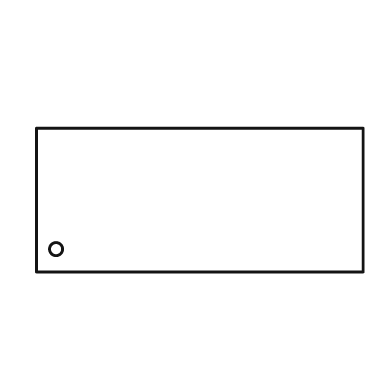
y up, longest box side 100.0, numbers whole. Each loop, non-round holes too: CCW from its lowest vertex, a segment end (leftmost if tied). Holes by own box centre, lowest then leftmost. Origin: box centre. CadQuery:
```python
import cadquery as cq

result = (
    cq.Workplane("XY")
    .moveTo(-50.0, -22.0)
    .lineTo(50.0, -22.0)
    .lineTo(50.0, 22.0)
    .lineTo(-50.0, 22.0)
    .close()
    .moveTo(-44.0, -15.0)
    .circle(2.0)
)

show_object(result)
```